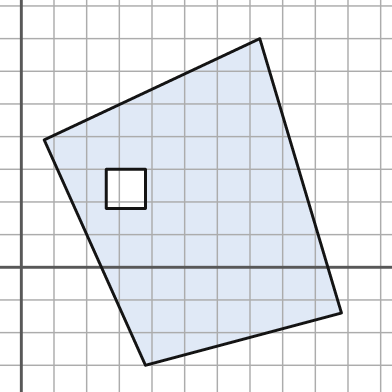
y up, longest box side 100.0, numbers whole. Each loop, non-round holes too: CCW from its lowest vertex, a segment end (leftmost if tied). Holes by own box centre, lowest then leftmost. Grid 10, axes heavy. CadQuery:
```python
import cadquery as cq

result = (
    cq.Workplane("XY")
    .moveTo(38.0, -30.0)
    .lineTo(98.0, -14.0)
    .lineTo(73.0, 70.0)
    .lineTo(7.0, 39.0)
    .close()
    .moveTo(26.0, 18.0)
    .lineTo(38.0, 18.0)
    .lineTo(38.0, 30.0)
    .lineTo(26.0, 30.0)
    .close()
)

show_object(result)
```